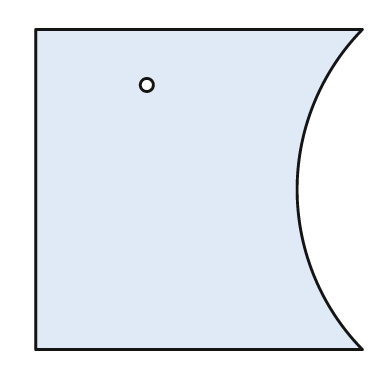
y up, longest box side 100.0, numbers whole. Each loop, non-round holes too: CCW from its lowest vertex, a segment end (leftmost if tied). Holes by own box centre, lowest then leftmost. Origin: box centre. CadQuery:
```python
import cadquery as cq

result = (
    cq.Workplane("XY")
    .moveTo(-50.0, -49.0)
    .lineTo(50.0, -49.0)
    .threePointArc((30.0, 0.0), (50.0, 49.0))
    .lineTo(-50.0, 49.0)
    .close()
    .moveTo(-16.0, 32.0)
    .circle(2.0)
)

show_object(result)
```